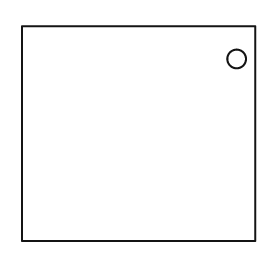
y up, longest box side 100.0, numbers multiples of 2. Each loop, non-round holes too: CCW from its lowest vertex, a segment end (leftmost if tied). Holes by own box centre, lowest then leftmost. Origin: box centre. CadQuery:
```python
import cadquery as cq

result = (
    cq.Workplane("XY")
    .moveTo(-50.0, -46.0)
    .lineTo(50.0, -46.0)
    .lineTo(50.0, 46.0)
    .lineTo(-50.0, 46.0)
    .close()
    .moveTo(42.0, 32.0)
    .circle(4.0)
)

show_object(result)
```